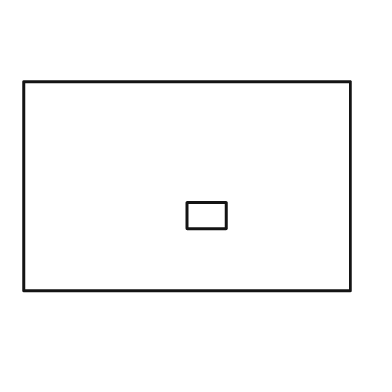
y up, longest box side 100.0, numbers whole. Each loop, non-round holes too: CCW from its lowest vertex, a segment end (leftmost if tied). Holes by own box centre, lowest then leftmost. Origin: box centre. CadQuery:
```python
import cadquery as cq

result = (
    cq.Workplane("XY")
    .moveTo(-50.0, -32.0)
    .lineTo(50.0, -32.0)
    .lineTo(50.0, 32.0)
    .lineTo(-50.0, 32.0)
    .close()
    .moveTo(0.0, -13.0)
    .lineTo(12.0, -13.0)
    .lineTo(12.0, -5.0)
    .lineTo(0.0, -5.0)
    .close()
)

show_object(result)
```